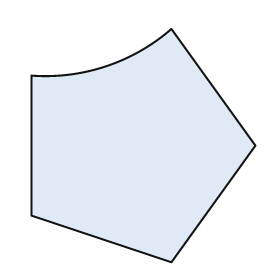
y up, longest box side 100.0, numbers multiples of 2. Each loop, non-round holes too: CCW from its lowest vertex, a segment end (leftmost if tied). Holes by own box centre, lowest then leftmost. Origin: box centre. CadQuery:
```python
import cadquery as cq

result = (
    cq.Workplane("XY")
    .moveTo(12.0, -50.0)
    .lineTo(48.0, 0.0)
    .lineTo(12.0, 50.0)
    .threePointArc((-16.0, 34.0), (-48.0, 30.0))
    .lineTo(-48.0, -30.0)
    .close()
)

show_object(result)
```